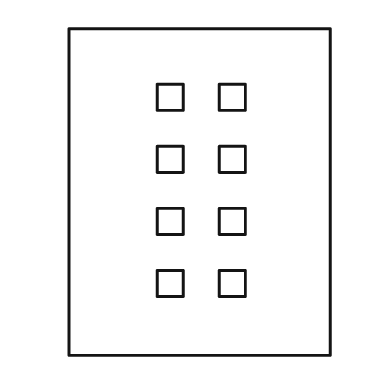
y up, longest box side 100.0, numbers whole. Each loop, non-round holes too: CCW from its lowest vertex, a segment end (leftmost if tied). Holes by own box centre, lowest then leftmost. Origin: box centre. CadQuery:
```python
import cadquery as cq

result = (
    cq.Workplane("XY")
    .moveTo(-40.0, -50.0)
    .lineTo(40.0, -50.0)
    .lineTo(40.0, 50.0)
    .lineTo(-40.0, 50.0)
    .close()
    .moveTo(-13.0, -32.0)
    .lineTo(-5.0, -32.0)
    .lineTo(-5.0, -24.0)
    .lineTo(-13.0, -24.0)
    .close()
    .moveTo(6.0, -32.0)
    .lineTo(14.0, -32.0)
    .lineTo(14.0, -24.0)
    .lineTo(6.0, -24.0)
    .close()
    .moveTo(-13.0, -13.0)
    .lineTo(-5.0, -13.0)
    .lineTo(-5.0, -5.0)
    .lineTo(-13.0, -5.0)
    .close()
    .moveTo(6.0, -13.0)
    .lineTo(14.0, -13.0)
    .lineTo(14.0, -5.0)
    .lineTo(6.0, -5.0)
    .close()
    .moveTo(-13.0, 6.0)
    .lineTo(-5.0, 6.0)
    .lineTo(-5.0, 14.0)
    .lineTo(-13.0, 14.0)
    .close()
    .moveTo(6.0, 6.0)
    .lineTo(14.0, 6.0)
    .lineTo(14.0, 14.0)
    .lineTo(6.0, 14.0)
    .close()
    .moveTo(-13.0, 25.0)
    .lineTo(-5.0, 25.0)
    .lineTo(-5.0, 33.0)
    .lineTo(-13.0, 33.0)
    .close()
    .moveTo(6.0, 25.0)
    .lineTo(14.0, 25.0)
    .lineTo(14.0, 33.0)
    .lineTo(6.0, 33.0)
    .close()
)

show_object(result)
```